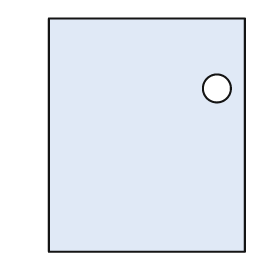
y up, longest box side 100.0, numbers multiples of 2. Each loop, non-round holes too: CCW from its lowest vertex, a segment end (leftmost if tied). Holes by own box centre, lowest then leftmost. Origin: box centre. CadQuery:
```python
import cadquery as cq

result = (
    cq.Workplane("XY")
    .moveTo(-42.0, -50.0)
    .lineTo(42.0, -50.0)
    .lineTo(42.0, 50.0)
    .lineTo(-42.0, 50.0)
    .close()
    .moveTo(30.0, 20.0)
    .circle(6.0)
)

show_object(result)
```